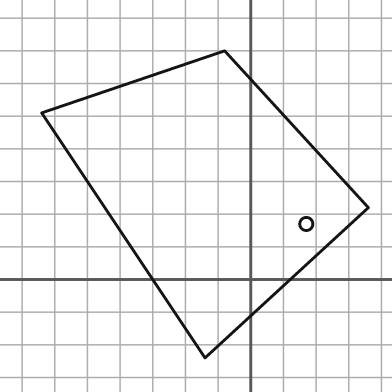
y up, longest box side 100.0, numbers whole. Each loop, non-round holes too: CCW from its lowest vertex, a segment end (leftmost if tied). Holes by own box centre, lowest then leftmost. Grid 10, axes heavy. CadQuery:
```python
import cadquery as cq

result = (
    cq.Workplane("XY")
    .moveTo(-14.0, -24.0)
    .lineTo(36.0, 22.0)
    .lineTo(-8.0, 70.0)
    .lineTo(-64.0, 51.0)
    .close()
    .moveTo(17.0, 17.0)
    .circle(2.0)
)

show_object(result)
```